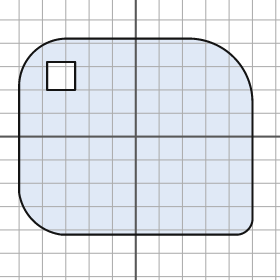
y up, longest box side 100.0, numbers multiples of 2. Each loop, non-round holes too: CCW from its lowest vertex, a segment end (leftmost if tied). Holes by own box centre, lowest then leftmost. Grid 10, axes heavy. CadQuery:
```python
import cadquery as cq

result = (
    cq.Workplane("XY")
    .moveTo(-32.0, -42.0)
    .lineTo(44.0, -42.0)
    .threePointArc((48.0, -40.0), (50.0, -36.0))
    .lineTo(50.0, 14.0)
    .threePointArc((42.0, 34.0), (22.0, 42.0))
    .lineTo(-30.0, 42.0)
    .threePointArc((-44.0, 36.0), (-50.0, 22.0))
    .lineTo(-50.0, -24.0)
    .threePointArc((-44.0, -36.0), (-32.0, -42.0))
    .close()
    .moveTo(-38.0, 20.0)
    .lineTo(-26.0, 20.0)
    .lineTo(-26.0, 32.0)
    .lineTo(-38.0, 32.0)
    .close()
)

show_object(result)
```